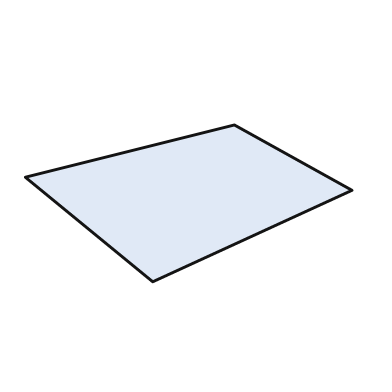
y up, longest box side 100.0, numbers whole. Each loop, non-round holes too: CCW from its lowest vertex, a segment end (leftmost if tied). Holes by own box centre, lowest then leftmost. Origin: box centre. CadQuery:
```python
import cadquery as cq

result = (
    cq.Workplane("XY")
    .moveTo(-11.0, -24.0)
    .lineTo(50.0, 4.0)
    .lineTo(14.0, 24.0)
    .lineTo(-50.0, 8.0)
    .close()
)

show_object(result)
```